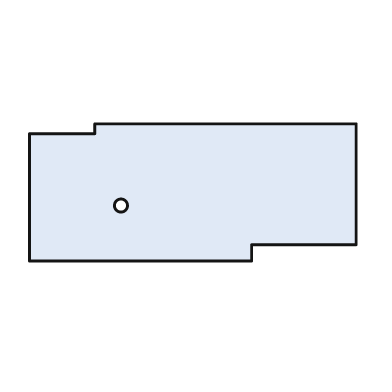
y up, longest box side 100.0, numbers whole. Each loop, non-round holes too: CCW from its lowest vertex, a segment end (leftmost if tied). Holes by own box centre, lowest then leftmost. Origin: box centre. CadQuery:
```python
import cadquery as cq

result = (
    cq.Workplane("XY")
    .moveTo(-50.0, -21.0)
    .lineTo(18.0, -21.0)
    .lineTo(18.0, -16.0)
    .lineTo(50.0, -16.0)
    .lineTo(50.0, 21.0)
    .lineTo(-30.0, 21.0)
    .lineTo(-30.0, 18.0)
    .lineTo(-50.0, 18.0)
    .close()
    .moveTo(-22.0, -4.0)
    .circle(2.0)
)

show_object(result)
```